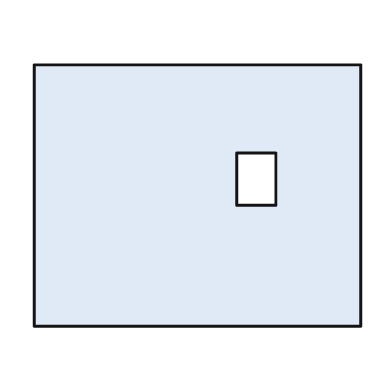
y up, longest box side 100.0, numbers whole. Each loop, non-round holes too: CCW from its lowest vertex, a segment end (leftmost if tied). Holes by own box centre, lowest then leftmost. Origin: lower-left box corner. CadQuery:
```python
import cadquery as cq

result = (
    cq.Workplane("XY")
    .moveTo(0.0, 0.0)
    .lineTo(100.0, 0.0)
    .lineTo(100.0, 80.0)
    .lineTo(0.0, 80.0)
    .close()
    .moveTo(62.0, 37.0)
    .lineTo(74.0, 37.0)
    .lineTo(74.0, 53.0)
    .lineTo(62.0, 53.0)
    .close()
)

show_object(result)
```